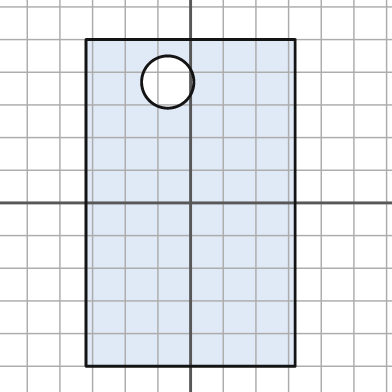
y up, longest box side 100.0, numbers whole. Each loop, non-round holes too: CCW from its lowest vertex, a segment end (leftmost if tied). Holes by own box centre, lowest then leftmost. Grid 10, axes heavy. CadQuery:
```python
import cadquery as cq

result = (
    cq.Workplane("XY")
    .moveTo(-32.0, -50.0)
    .lineTo(32.0, -50.0)
    .lineTo(32.0, 50.0)
    .lineTo(-32.0, 50.0)
    .close()
    .moveTo(-7.0, 37.0)
    .circle(8.0)
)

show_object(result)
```